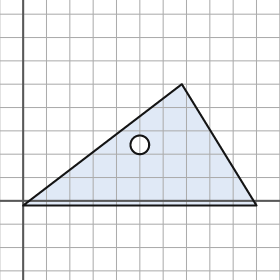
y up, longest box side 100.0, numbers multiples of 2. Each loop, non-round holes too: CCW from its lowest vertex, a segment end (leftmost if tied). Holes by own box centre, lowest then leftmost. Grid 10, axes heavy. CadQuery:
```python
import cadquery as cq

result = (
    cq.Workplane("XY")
    .moveTo(0.0, -2.0)
    .lineTo(100.0, -2.0)
    .lineTo(68.0, 50.0)
    .close()
    .moveTo(50.0, 24.0)
    .circle(4.0)
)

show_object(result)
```